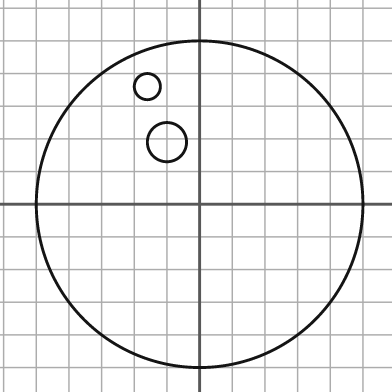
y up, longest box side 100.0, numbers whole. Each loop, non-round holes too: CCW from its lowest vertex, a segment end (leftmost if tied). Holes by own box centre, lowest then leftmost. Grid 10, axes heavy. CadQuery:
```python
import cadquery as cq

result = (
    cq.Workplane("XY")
    .moveTo(0.0, 0.0)
    .circle(50.0)
    .moveTo(-10.0, 19.0)
    .circle(6.0)
    .moveTo(-16.0, 36.0)
    .circle(4.0)
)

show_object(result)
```